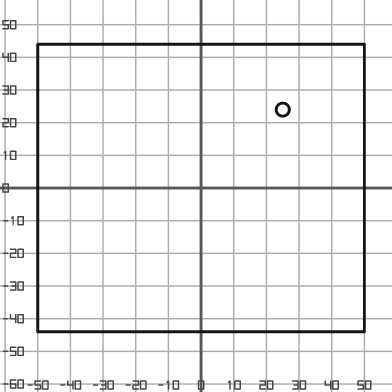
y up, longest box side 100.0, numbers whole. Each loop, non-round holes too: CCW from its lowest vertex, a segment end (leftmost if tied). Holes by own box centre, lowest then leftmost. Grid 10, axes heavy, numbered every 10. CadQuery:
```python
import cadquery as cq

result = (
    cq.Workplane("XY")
    .moveTo(-50.0, -44.0)
    .lineTo(50.0, -44.0)
    .lineTo(50.0, 44.0)
    .lineTo(-50.0, 44.0)
    .close()
    .moveTo(25.0, 24.0)
    .circle(2.0)
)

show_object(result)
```